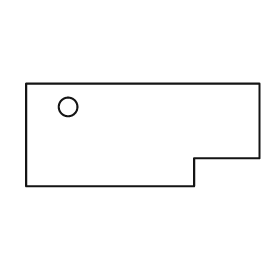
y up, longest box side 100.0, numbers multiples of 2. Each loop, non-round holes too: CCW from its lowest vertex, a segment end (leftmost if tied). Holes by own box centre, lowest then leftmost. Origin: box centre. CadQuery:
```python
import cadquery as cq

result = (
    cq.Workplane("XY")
    .moveTo(-50.0, -22.0)
    .lineTo(22.0, -22.0)
    .lineTo(22.0, -10.0)
    .lineTo(50.0, -10.0)
    .lineTo(50.0, 22.0)
    .lineTo(-50.0, 22.0)
    .close()
    .moveTo(-32.0, 12.0)
    .circle(4.0)
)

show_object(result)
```